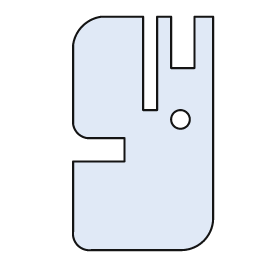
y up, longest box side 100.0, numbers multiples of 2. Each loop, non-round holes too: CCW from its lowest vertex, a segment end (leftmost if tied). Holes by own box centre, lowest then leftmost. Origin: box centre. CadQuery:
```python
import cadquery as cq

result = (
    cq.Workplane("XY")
    .moveTo(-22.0, -50.0)
    .lineTo(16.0, -50.0)
    .threePointArc((26.0, -46.0), (30.0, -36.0))
    .lineTo(30.0, 50.0)
    .lineTo(22.0, 50.0)
    .lineTo(22.0, 28.0)
    .lineTo(12.0, 28.0)
    .lineTo(12.0, 50.0)
    .lineTo(6.0, 50.0)
    .lineTo(6.0, 10.0)
    .lineTo(0.0, 10.0)
    .lineTo(0.0, 50.0)
    .lineTo(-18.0, 50.0)
    .threePointArc((-26.0, 46.0), (-30.0, 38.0))
    .lineTo(-30.0, 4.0)
    .threePointArc((-28.0, 0.0), (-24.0, -2.0))
    .lineTo(-8.0, -2.0)
    .lineTo(-8.0, -12.0)
    .lineTo(-30.0, -12.0)
    .lineTo(-30.0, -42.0)
    .threePointArc((-28.0, -48.0), (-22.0, -50.0))
    .close()
    .moveTo(16.0, 6.0)
    .circle(4.0)
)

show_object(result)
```